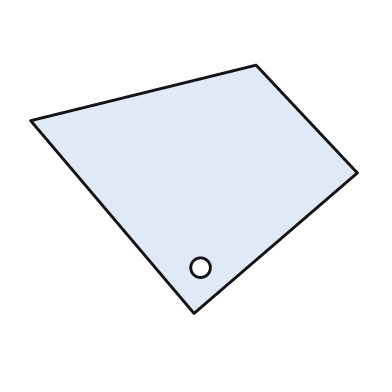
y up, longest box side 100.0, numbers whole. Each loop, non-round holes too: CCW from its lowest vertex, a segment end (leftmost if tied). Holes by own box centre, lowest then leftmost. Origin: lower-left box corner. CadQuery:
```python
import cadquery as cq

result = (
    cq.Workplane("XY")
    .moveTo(50.0, 0.0)
    .lineTo(100.0, 43.0)
    .lineTo(69.0, 76.0)
    .lineTo(0.0, 59.0)
    .close()
    .moveTo(52.0, 14.0)
    .circle(3.0)
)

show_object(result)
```